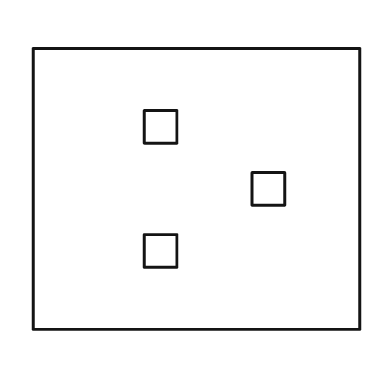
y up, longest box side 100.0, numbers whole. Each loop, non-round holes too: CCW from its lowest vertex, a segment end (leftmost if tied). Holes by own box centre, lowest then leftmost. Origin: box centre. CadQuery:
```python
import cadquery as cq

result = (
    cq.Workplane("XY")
    .moveTo(-50.0, -43.0)
    .lineTo(50.0, -43.0)
    .lineTo(50.0, 43.0)
    .lineTo(-50.0, 43.0)
    .close()
    .moveTo(-16.0, -24.0)
    .lineTo(-6.0, -24.0)
    .lineTo(-6.0, -14.0)
    .lineTo(-16.0, -14.0)
    .close()
    .moveTo(17.0, -5.0)
    .lineTo(27.0, -5.0)
    .lineTo(27.0, 5.0)
    .lineTo(17.0, 5.0)
    .close()
    .moveTo(-16.0, 14.0)
    .lineTo(-6.0, 14.0)
    .lineTo(-6.0, 24.0)
    .lineTo(-16.0, 24.0)
    .close()
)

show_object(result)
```